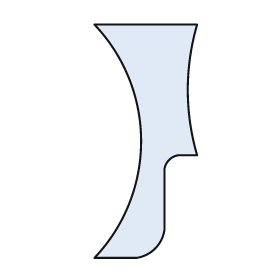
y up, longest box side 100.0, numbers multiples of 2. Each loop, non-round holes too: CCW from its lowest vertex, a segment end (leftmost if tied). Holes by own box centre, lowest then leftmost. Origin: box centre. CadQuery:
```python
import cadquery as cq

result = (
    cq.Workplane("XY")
    .moveTo(-22.0, -50.0)
    .lineTo(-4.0, -50.0)
    .threePointArc((4.0, -46.0), (8.0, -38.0))
    .lineTo(8.0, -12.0)
    .threePointArc((10.0, -8.0), (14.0, -6.0))
    .lineTo(22.0, -6.0)
    .threePointArc((18.0, 22.0), (22.0, 50.0))
    .lineTo(-22.0, 50.0)
    .threePointArc((-2.0, 0.0), (-22.0, -50.0))
    .close()
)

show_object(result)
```